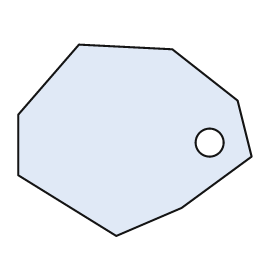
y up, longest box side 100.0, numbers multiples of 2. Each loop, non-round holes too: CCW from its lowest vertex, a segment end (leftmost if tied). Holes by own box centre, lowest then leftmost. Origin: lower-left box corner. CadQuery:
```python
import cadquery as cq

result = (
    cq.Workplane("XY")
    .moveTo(42.0, 0.0)
    .lineTo(70.0, 12.0)
    .lineTo(100.0, 34.0)
    .lineTo(94.0, 58.0)
    .lineTo(66.0, 80.0)
    .lineTo(26.0, 82.0)
    .lineTo(0.0, 52.0)
    .lineTo(0.0, 26.0)
    .close()
    .moveTo(82.0, 40.0)
    .circle(6.0)
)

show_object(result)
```